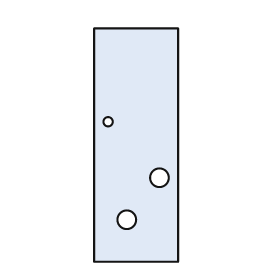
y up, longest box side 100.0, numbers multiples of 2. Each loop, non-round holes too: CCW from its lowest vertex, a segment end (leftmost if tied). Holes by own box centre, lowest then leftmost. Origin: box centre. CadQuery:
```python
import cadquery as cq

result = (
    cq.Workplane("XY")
    .moveTo(-18.0, -50.0)
    .lineTo(18.0, -50.0)
    .lineTo(18.0, 50.0)
    .lineTo(-18.0, 50.0)
    .close()
    .moveTo(-4.0, -32.0)
    .circle(4.0)
    .moveTo(10.0, -14.0)
    .circle(4.0)
    .moveTo(-12.0, 10.0)
    .circle(2.0)
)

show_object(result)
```